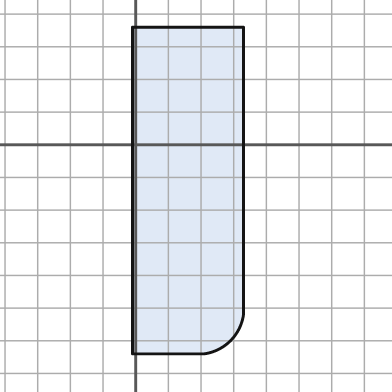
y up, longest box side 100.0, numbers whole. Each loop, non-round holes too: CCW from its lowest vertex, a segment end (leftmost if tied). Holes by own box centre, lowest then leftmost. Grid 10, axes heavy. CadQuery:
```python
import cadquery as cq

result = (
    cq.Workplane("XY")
    .moveTo(-1.0, -64.0)
    .lineTo(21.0, -64.0)
    .threePointArc((29.0, -60.0), (33.0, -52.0))
    .lineTo(33.0, 36.0)
    .lineTo(-1.0, 36.0)
    .close()
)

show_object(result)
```